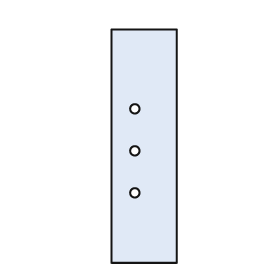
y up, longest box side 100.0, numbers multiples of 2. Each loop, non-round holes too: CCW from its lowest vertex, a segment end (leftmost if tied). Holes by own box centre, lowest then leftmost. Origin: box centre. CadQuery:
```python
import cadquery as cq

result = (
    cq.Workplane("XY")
    .moveTo(-14.0, -50.0)
    .lineTo(14.0, -50.0)
    .lineTo(14.0, 50.0)
    .lineTo(-14.0, 50.0)
    .close()
    .moveTo(-4.0, -20.0)
    .circle(2.0)
    .moveTo(-4.0, -2.0)
    .circle(2.0)
    .moveTo(-4.0, 16.0)
    .circle(2.0)
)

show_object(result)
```